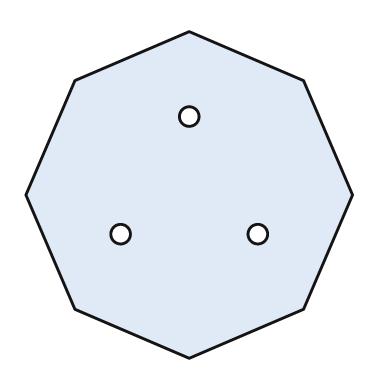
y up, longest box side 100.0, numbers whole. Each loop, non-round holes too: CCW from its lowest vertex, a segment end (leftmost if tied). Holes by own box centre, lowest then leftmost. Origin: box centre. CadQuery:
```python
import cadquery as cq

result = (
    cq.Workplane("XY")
    .moveTo(0.0, -50.0)
    .lineTo(35.0, -35.0)
    .lineTo(50.0, 0.0)
    .lineTo(35.0, 35.0)
    .lineTo(0.0, 50.0)
    .lineTo(-35.0, 35.0)
    .lineTo(-50.0, 0.0)
    .lineTo(-35.0, -35.0)
    .close()
    .moveTo(-21.0, -12.0)
    .circle(3.0)
    .moveTo(21.0, -12.0)
    .circle(3.0)
    .moveTo(0.0, 24.0)
    .circle(3.0)
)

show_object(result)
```